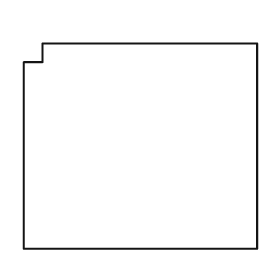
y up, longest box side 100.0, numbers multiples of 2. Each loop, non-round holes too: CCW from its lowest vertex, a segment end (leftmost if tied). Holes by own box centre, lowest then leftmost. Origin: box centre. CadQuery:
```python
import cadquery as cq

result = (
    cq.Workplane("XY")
    .moveTo(-50.0, -44.0)
    .lineTo(50.0, -44.0)
    .lineTo(50.0, 44.0)
    .lineTo(-42.0, 44.0)
    .lineTo(-42.0, 36.0)
    .lineTo(-50.0, 36.0)
    .close()
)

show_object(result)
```